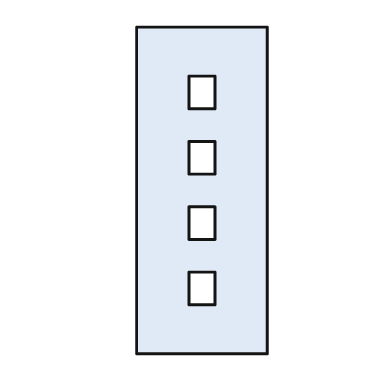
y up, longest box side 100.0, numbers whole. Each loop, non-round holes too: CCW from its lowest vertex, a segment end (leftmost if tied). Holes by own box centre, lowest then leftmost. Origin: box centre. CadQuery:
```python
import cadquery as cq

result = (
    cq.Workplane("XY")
    .moveTo(-20.0, -50.0)
    .lineTo(20.0, -50.0)
    .lineTo(20.0, 50.0)
    .lineTo(-20.0, 50.0)
    .close()
    .moveTo(-4.0, -35.0)
    .lineTo(4.0, -35.0)
    .lineTo(4.0, -25.0)
    .lineTo(-4.0, -25.0)
    .close()
    .moveTo(-4.0, -15.0)
    .lineTo(4.0, -15.0)
    .lineTo(4.0, -5.0)
    .lineTo(-4.0, -5.0)
    .close()
    .moveTo(-4.0, 5.0)
    .lineTo(4.0, 5.0)
    .lineTo(4.0, 15.0)
    .lineTo(-4.0, 15.0)
    .close()
    .moveTo(-4.0, 25.0)
    .lineTo(4.0, 25.0)
    .lineTo(4.0, 35.0)
    .lineTo(-4.0, 35.0)
    .close()
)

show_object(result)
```